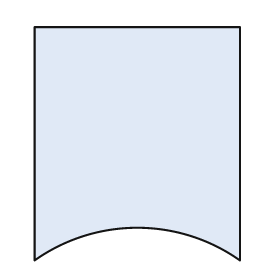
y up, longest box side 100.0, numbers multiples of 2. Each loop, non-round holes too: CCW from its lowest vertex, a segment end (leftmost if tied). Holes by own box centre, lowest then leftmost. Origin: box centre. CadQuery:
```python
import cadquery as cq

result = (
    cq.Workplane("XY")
    .moveTo(-44.0, -50.0)
    .threePointArc((0.0, -36.0), (44.0, -50.0))
    .lineTo(44.0, 50.0)
    .lineTo(-44.0, 50.0)
    .close()
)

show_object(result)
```